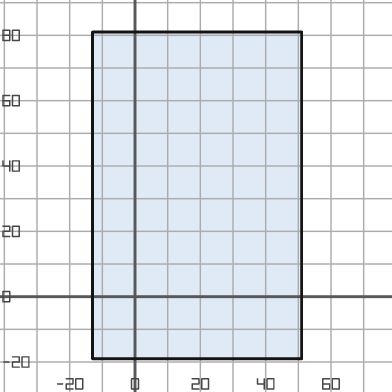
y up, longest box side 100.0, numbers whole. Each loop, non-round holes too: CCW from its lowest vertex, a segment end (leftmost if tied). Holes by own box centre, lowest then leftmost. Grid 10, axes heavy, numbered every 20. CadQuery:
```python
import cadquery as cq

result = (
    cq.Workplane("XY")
    .moveTo(-13.0, -19.0)
    .lineTo(51.0, -19.0)
    .lineTo(51.0, 81.0)
    .lineTo(-13.0, 81.0)
    .close()
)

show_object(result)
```